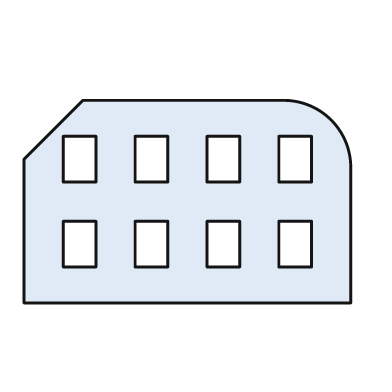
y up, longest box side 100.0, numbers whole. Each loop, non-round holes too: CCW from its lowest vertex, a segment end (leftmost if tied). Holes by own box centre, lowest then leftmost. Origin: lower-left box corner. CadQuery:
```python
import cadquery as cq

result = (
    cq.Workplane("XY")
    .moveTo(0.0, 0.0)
    .lineTo(100.0, 0.0)
    .lineTo(100.0, 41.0)
    .threePointArc((94.0, 56.0), (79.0, 62.0))
    .lineTo(18.0, 62.0)
    .lineTo(0.0, 44.0)
    .close()
    .moveTo(12.0, 11.0)
    .lineTo(22.0, 11.0)
    .lineTo(22.0, 25.0)
    .lineTo(12.0, 25.0)
    .close()
    .moveTo(34.0, 11.0)
    .lineTo(44.0, 11.0)
    .lineTo(44.0, 25.0)
    .lineTo(34.0, 25.0)
    .close()
    .moveTo(56.0, 11.0)
    .lineTo(66.0, 11.0)
    .lineTo(66.0, 25.0)
    .lineTo(56.0, 25.0)
    .close()
    .moveTo(78.0, 11.0)
    .lineTo(88.0, 11.0)
    .lineTo(88.0, 25.0)
    .lineTo(78.0, 25.0)
    .close()
    .moveTo(12.0, 37.0)
    .lineTo(22.0, 37.0)
    .lineTo(22.0, 51.0)
    .lineTo(12.0, 51.0)
    .close()
    .moveTo(34.0, 37.0)
    .lineTo(44.0, 37.0)
    .lineTo(44.0, 51.0)
    .lineTo(34.0, 51.0)
    .close()
    .moveTo(56.0, 37.0)
    .lineTo(66.0, 37.0)
    .lineTo(66.0, 51.0)
    .lineTo(56.0, 51.0)
    .close()
    .moveTo(78.0, 37.0)
    .lineTo(88.0, 37.0)
    .lineTo(88.0, 51.0)
    .lineTo(78.0, 51.0)
    .close()
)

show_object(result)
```